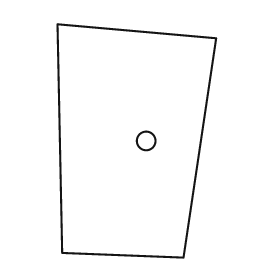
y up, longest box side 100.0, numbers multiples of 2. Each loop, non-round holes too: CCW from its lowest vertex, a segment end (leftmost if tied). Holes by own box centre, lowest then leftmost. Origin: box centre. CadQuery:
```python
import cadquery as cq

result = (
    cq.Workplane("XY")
    .moveTo(20.0, -50.0)
    .lineTo(34.0, 44.0)
    .lineTo(-34.0, 50.0)
    .lineTo(-32.0, -48.0)
    .close()
    .moveTo(4.0, 0.0)
    .circle(4.0)
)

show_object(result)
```